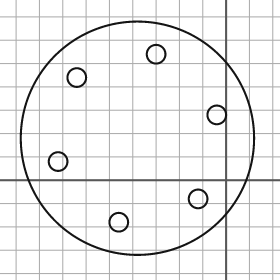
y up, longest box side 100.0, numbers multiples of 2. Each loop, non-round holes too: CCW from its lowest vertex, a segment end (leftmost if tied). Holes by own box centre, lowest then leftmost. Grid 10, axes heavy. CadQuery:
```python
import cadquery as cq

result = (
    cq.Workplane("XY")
    .moveTo(-38.0, 18.0)
    .circle(50.0)
    .moveTo(-46.0, -18.0)
    .circle(4.0)
    .moveTo(-12.0, -8.0)
    .circle(4.0)
    .moveTo(-72.0, 8.0)
    .circle(4.0)
    .moveTo(-4.0, 28.0)
    .circle(4.0)
    .moveTo(-64.0, 44.0)
    .circle(4.0)
    .moveTo(-30.0, 54.0)
    .circle(4.0)
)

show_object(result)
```